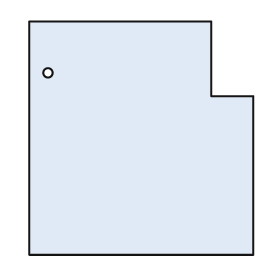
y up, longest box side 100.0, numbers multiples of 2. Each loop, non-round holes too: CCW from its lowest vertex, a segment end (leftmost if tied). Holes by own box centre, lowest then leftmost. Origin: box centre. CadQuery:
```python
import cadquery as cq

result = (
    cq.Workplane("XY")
    .moveTo(-48.0, -50.0)
    .lineTo(48.0, -50.0)
    .lineTo(48.0, 18.0)
    .lineTo(30.0, 18.0)
    .lineTo(30.0, 50.0)
    .lineTo(-48.0, 50.0)
    .close()
    .moveTo(-40.0, 28.0)
    .circle(2.0)
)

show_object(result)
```